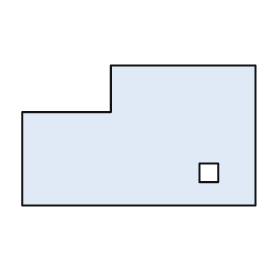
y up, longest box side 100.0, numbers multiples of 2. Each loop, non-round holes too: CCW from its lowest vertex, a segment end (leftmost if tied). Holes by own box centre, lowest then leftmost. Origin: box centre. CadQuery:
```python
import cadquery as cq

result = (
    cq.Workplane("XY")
    .moveTo(-50.0, -30.0)
    .lineTo(50.0, -30.0)
    .lineTo(50.0, 30.0)
    .lineTo(-12.0, 30.0)
    .lineTo(-12.0, 10.0)
    .lineTo(-50.0, 10.0)
    .close()
    .moveTo(26.0, -20.0)
    .lineTo(34.0, -20.0)
    .lineTo(34.0, -12.0)
    .lineTo(26.0, -12.0)
    .close()
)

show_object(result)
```